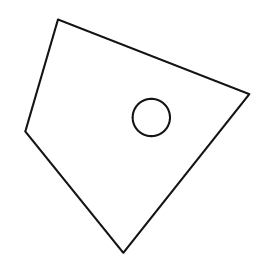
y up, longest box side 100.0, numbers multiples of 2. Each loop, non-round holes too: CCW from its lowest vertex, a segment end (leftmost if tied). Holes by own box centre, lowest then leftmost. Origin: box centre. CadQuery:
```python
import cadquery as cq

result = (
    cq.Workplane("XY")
    .moveTo(-6.0, -50.0)
    .lineTo(48.0, 18.0)
    .lineTo(-34.0, 50.0)
    .lineTo(-48.0, 2.0)
    .close()
    .moveTo(6.0, 8.0)
    .circle(8.0)
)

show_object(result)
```